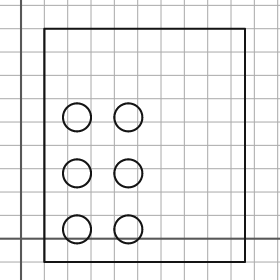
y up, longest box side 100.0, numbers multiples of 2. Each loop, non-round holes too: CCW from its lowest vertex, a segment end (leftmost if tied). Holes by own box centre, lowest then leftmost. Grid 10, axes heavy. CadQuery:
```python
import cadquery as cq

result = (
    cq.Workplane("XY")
    .moveTo(10.0, -10.0)
    .lineTo(96.0, -10.0)
    .lineTo(96.0, 90.0)
    .lineTo(10.0, 90.0)
    .close()
    .moveTo(24.0, 4.0)
    .circle(6.0)
    .moveTo(46.0, 4.0)
    .circle(6.0)
    .moveTo(24.0, 28.0)
    .circle(6.0)
    .moveTo(46.0, 28.0)
    .circle(6.0)
    .moveTo(24.0, 52.0)
    .circle(6.0)
    .moveTo(46.0, 52.0)
    .circle(6.0)
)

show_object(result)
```